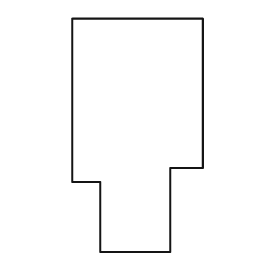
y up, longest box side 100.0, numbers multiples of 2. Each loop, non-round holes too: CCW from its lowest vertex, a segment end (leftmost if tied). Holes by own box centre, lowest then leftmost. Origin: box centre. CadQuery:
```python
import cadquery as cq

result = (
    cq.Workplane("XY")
    .moveTo(-16.0, -50.0)
    .lineTo(14.0, -50.0)
    .lineTo(14.0, -14.0)
    .lineTo(28.0, -14.0)
    .lineTo(28.0, 50.0)
    .lineTo(-28.0, 50.0)
    .lineTo(-28.0, -20.0)
    .lineTo(-16.0, -20.0)
    .close()
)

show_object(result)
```